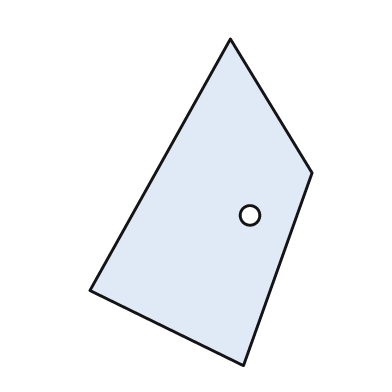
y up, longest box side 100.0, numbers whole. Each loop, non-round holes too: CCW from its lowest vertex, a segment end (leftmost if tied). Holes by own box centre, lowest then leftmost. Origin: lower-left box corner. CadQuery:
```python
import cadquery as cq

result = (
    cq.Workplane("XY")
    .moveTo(47.0, 0.0)
    .lineTo(68.0, 59.0)
    .lineTo(43.0, 100.0)
    .lineTo(0.0, 23.0)
    .close()
    .moveTo(49.0, 46.0)
    .circle(3.0)
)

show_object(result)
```